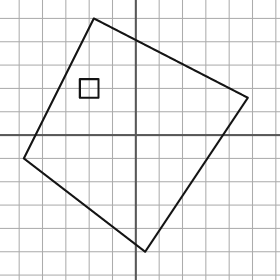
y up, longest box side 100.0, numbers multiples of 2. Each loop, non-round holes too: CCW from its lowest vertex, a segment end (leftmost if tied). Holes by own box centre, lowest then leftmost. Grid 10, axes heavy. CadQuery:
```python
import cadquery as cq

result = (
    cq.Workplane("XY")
    .moveTo(4.0, -50.0)
    .lineTo(48.0, 16.0)
    .lineTo(-18.0, 50.0)
    .lineTo(-48.0, -10.0)
    .close()
    .moveTo(-24.0, 16.0)
    .lineTo(-16.0, 16.0)
    .lineTo(-16.0, 24.0)
    .lineTo(-24.0, 24.0)
    .close()
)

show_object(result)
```